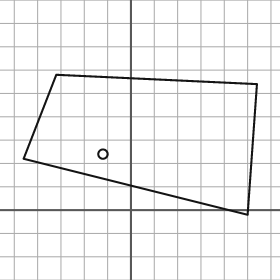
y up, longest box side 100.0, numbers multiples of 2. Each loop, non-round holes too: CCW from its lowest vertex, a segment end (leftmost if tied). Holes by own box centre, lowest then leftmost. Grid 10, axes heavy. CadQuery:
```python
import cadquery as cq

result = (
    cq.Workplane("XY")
    .moveTo(50.0, -2.0)
    .lineTo(54.0, 54.0)
    .lineTo(-32.0, 58.0)
    .lineTo(-46.0, 22.0)
    .close()
    .moveTo(-12.0, 24.0)
    .circle(2.0)
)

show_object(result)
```